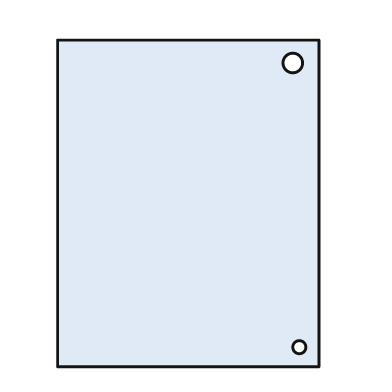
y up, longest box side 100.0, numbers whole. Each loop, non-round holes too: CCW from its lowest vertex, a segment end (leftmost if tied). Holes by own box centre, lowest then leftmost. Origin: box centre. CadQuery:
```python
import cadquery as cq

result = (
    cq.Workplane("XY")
    .moveTo(-40.0, -50.0)
    .lineTo(40.0, -50.0)
    .lineTo(40.0, 50.0)
    .lineTo(-40.0, 50.0)
    .close()
    .moveTo(34.0, -44.0)
    .circle(2.0)
    .moveTo(32.0, 43.0)
    .circle(3.0)
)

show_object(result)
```